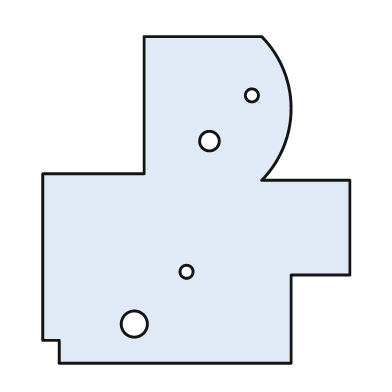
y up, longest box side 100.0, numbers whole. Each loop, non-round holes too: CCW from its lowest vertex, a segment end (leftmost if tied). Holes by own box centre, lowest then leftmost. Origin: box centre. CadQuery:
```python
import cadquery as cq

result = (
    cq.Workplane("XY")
    .moveTo(-42.0, -50.0)
    .lineTo(29.0, -50.0)
    .lineTo(29.0, -23.0)
    .lineTo(47.0, -23.0)
    .lineTo(47.0, 6.0)
    .lineTo(20.0, 6.0)
    .threePointArc((29.0, 28.0), (20.0, 50.0))
    .lineTo(-16.0, 50.0)
    .lineTo(-16.0, 8.0)
    .lineTo(-47.0, 8.0)
    .lineTo(-47.0, -43.0)
    .lineTo(-42.0, -43.0)
    .close()
    .moveTo(-19.0, -38.0)
    .circle(4.0)
    .moveTo(-3.0, -22.0)
    .circle(2.0)
    .moveTo(4.0, 18.0)
    .circle(3.0)
    .moveTo(17.0, 32.0)
    .circle(2.0)
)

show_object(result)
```